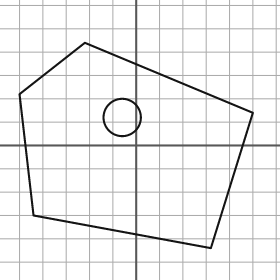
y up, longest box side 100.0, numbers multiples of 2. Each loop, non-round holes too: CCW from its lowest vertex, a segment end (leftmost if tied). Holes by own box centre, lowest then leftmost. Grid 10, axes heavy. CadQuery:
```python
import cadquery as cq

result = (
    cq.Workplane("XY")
    .moveTo(32.0, -44.0)
    .lineTo(50.0, 14.0)
    .lineTo(-22.0, 44.0)
    .lineTo(-50.0, 22.0)
    .lineTo(-44.0, -30.0)
    .close()
    .moveTo(-6.0, 12.0)
    .circle(8.0)
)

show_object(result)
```